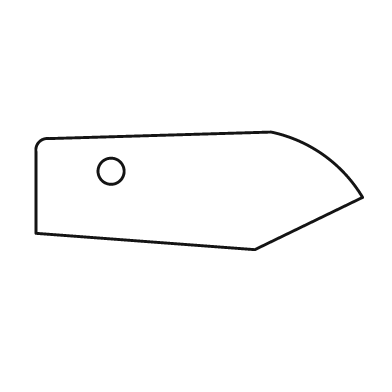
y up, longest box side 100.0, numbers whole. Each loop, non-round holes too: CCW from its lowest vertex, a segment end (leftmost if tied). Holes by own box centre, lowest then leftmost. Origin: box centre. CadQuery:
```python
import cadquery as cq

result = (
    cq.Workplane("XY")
    .moveTo(17.0, -18.0)
    .lineTo(50.0, -2.0)
    .threePointArc((38.0, 11.0), (22.0, 18.0))
    .lineTo(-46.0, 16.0)
    .threePointArc((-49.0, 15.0), (-50.0, 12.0))
    .lineTo(-50.0, -13.0)
    .close()
    .moveTo(-27.0, 6.0)
    .circle(4.0)
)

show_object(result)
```